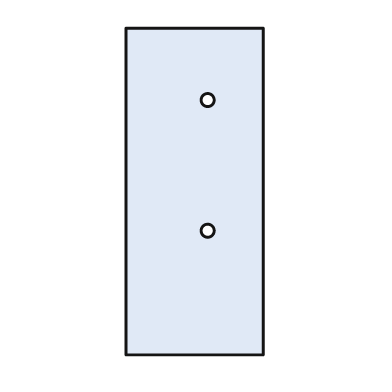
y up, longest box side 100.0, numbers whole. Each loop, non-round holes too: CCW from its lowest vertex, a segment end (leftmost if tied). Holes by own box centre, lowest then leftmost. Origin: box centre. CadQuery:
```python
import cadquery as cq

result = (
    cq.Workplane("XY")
    .moveTo(-21.0, -50.0)
    .lineTo(21.0, -50.0)
    .lineTo(21.0, 50.0)
    .lineTo(-21.0, 50.0)
    .close()
    .moveTo(4.0, -12.0)
    .circle(2.0)
    .moveTo(4.0, 28.0)
    .circle(2.0)
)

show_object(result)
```